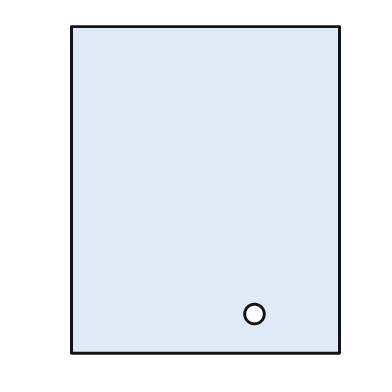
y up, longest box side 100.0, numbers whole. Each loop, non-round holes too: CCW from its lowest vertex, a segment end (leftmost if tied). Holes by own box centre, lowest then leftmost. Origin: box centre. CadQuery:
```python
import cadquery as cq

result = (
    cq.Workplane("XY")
    .moveTo(-41.0, -50.0)
    .lineTo(41.0, -50.0)
    .lineTo(41.0, 50.0)
    .lineTo(-41.0, 50.0)
    .close()
    .moveTo(15.0, -38.0)
    .circle(3.0)
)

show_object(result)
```